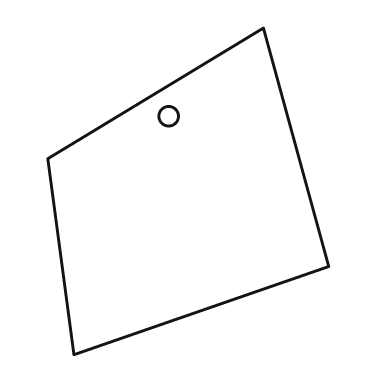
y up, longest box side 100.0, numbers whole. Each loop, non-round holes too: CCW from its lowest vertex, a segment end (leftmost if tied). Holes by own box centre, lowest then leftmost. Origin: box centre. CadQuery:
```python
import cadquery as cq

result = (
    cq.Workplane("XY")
    .moveTo(-35.0, -50.0)
    .lineTo(43.0, -23.0)
    .lineTo(23.0, 50.0)
    .lineTo(-43.0, 10.0)
    .close()
    .moveTo(-6.0, 23.0)
    .circle(3.0)
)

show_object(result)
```